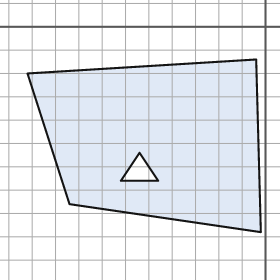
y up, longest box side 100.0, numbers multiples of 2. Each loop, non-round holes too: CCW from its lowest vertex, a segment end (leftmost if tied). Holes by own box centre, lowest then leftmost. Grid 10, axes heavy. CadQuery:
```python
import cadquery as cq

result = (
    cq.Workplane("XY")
    .moveTo(-2.0, -88.0)
    .lineTo(-4.0, -14.0)
    .lineTo(-102.0, -20.0)
    .lineTo(-84.0, -76.0)
    .close()
    .moveTo(-62.0, -66.0)
    .lineTo(-46.0, -66.0)
    .lineTo(-54.0, -54.0)
    .close()
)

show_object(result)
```